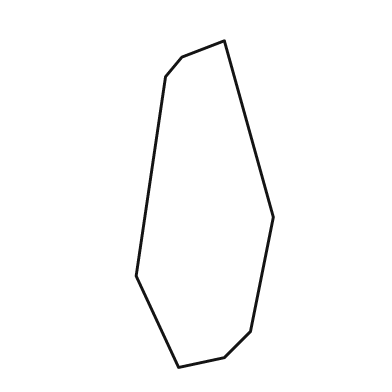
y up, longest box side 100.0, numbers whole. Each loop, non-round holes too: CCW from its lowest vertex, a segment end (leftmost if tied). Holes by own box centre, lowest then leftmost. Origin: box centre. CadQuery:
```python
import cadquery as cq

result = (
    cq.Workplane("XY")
    .moveTo(-8.0, -50.0)
    .lineTo(6.0, -47.0)
    .lineTo(14.0, -39.0)
    .lineTo(21.0, -4.0)
    .lineTo(6.0, 50.0)
    .lineTo(-7.0, 45.0)
    .lineTo(-12.0, 39.0)
    .lineTo(-21.0, -22.0)
    .close()
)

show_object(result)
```